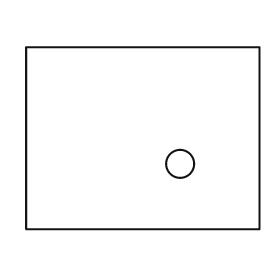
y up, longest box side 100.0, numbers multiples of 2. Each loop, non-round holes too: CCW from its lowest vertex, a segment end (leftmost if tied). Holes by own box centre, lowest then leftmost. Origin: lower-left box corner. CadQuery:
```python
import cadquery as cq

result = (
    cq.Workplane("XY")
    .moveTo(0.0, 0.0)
    .lineTo(100.0, 0.0)
    .lineTo(100.0, 78.0)
    .lineTo(0.0, 78.0)
    .close()
    .moveTo(66.0, 28.0)
    .circle(6.0)
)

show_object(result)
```